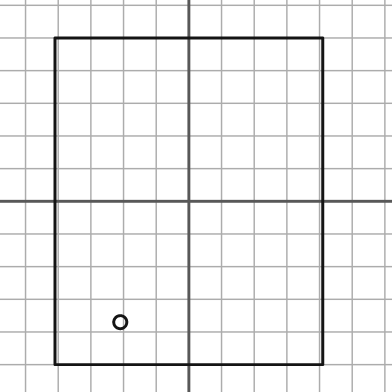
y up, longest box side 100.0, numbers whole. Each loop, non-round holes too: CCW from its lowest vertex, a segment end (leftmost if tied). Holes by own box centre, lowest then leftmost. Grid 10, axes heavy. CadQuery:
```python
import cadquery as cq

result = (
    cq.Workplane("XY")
    .moveTo(-41.0, -50.0)
    .lineTo(41.0, -50.0)
    .lineTo(41.0, 50.0)
    .lineTo(-41.0, 50.0)
    .close()
    .moveTo(-21.0, -37.0)
    .circle(2.0)
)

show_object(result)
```